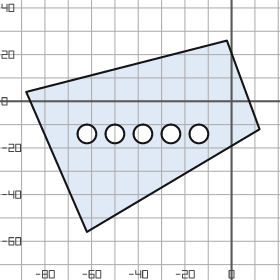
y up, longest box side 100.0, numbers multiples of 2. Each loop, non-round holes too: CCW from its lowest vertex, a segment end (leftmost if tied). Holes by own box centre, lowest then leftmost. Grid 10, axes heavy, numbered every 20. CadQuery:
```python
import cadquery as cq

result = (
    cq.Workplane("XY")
    .moveTo(-62.0, -56.0)
    .lineTo(12.0, -12.0)
    .lineTo(-2.0, 26.0)
    .lineTo(-88.0, 4.0)
    .close()
    .moveTo(-62.0, -14.0)
    .circle(4.0)
    .moveTo(-50.0, -14.0)
    .circle(4.0)
    .moveTo(-38.0, -14.0)
    .circle(4.0)
    .moveTo(-26.0, -14.0)
    .circle(4.0)
    .moveTo(-14.0, -14.0)
    .circle(4.0)
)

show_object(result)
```